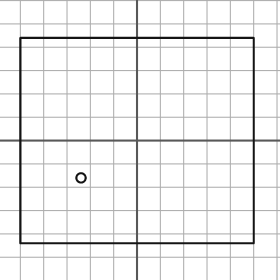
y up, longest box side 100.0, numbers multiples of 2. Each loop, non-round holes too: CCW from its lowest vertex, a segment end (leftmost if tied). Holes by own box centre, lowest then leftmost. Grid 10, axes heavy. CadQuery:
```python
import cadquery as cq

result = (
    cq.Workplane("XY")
    .moveTo(-50.0, -44.0)
    .lineTo(50.0, -44.0)
    .lineTo(50.0, 44.0)
    .lineTo(-50.0, 44.0)
    .close()
    .moveTo(-24.0, -16.0)
    .circle(2.0)
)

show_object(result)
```